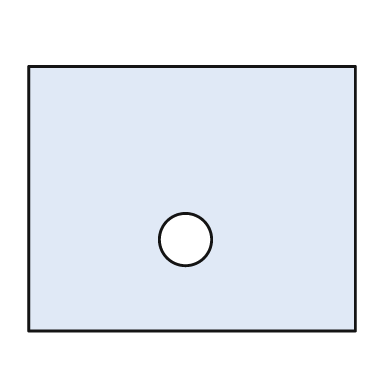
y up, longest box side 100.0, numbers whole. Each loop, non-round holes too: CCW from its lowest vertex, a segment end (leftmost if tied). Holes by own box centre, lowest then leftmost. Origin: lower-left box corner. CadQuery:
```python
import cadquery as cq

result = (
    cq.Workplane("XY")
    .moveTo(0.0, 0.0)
    .lineTo(100.0, 0.0)
    .lineTo(100.0, 81.0)
    .lineTo(0.0, 81.0)
    .close()
    .moveTo(48.0, 28.0)
    .circle(8.0)
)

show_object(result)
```